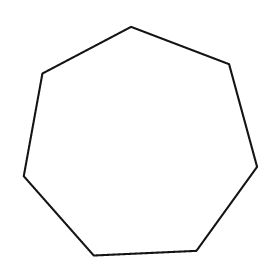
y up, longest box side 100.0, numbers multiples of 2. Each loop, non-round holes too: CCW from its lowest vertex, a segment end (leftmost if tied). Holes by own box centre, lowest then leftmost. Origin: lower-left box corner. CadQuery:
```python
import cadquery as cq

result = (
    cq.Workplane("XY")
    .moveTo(30.0, 0.0)
    .lineTo(74.0, 2.0)
    .lineTo(100.0, 38.0)
    .lineTo(88.0, 82.0)
    .lineTo(46.0, 98.0)
    .lineTo(8.0, 78.0)
    .lineTo(0.0, 34.0)
    .close()
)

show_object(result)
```